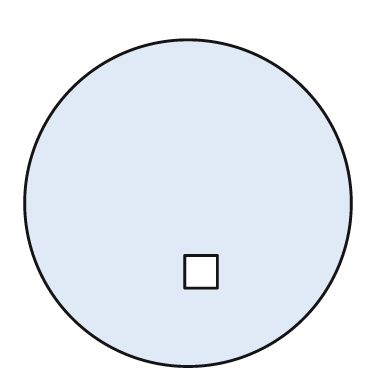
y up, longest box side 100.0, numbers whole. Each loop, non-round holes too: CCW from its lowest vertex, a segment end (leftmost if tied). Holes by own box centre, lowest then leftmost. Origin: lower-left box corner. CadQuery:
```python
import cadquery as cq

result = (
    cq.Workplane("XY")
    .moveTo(50.0, 50.0)
    .circle(50.0)
    .moveTo(49.0, 24.0)
    .lineTo(59.0, 24.0)
    .lineTo(59.0, 34.0)
    .lineTo(49.0, 34.0)
    .close()
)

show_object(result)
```